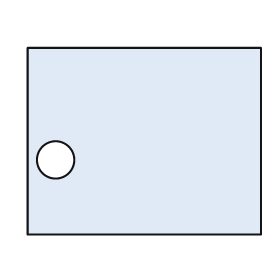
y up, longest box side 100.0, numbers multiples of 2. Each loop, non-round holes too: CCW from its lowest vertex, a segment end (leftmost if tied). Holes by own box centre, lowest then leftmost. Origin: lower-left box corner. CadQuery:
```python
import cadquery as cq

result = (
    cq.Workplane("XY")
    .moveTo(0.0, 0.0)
    .lineTo(100.0, 0.0)
    .lineTo(100.0, 80.0)
    .lineTo(0.0, 80.0)
    .close()
    .moveTo(12.0, 32.0)
    .circle(8.0)
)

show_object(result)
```